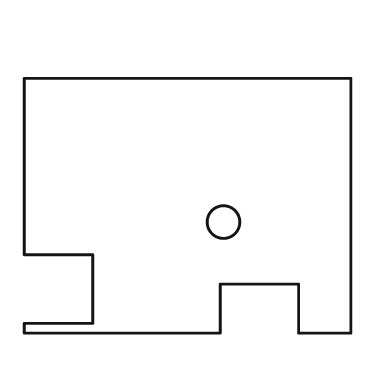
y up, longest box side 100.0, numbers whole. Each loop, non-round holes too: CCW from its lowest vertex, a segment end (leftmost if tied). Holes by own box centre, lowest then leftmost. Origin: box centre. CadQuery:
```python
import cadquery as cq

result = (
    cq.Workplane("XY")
    .moveTo(-50.0, -39.0)
    .lineTo(10.0, -39.0)
    .lineTo(10.0, -24.0)
    .lineTo(34.0, -24.0)
    .lineTo(34.0, -39.0)
    .lineTo(50.0, -39.0)
    .lineTo(50.0, 39.0)
    .lineTo(-50.0, 39.0)
    .lineTo(-50.0, -15.0)
    .lineTo(-29.0, -15.0)
    .lineTo(-29.0, -36.0)
    .lineTo(-50.0, -36.0)
    .close()
    .moveTo(11.0, -5.0)
    .circle(5.0)
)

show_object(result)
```